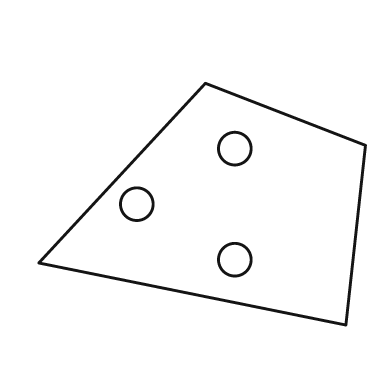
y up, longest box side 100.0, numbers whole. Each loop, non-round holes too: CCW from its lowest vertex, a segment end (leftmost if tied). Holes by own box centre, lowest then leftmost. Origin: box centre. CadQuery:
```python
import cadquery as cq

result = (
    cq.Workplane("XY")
    .moveTo(44.0, -37.0)
    .lineTo(50.0, 18.0)
    .lineTo(1.0, 37.0)
    .lineTo(-50.0, -18.0)
    .close()
    .moveTo(10.0, -17.0)
    .circle(5.0)
    .moveTo(-20.0, 0.0)
    .circle(5.0)
    .moveTo(10.0, 17.0)
    .circle(5.0)
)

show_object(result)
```